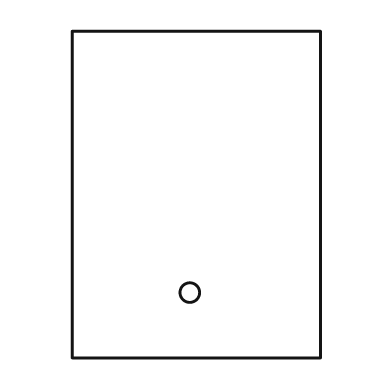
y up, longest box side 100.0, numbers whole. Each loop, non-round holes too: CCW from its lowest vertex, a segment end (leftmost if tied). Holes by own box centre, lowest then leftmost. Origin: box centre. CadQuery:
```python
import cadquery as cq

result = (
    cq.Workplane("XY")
    .moveTo(-38.0, -50.0)
    .lineTo(38.0, -50.0)
    .lineTo(38.0, 50.0)
    .lineTo(-38.0, 50.0)
    .close()
    .moveTo(-2.0, -30.0)
    .circle(3.0)
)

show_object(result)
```